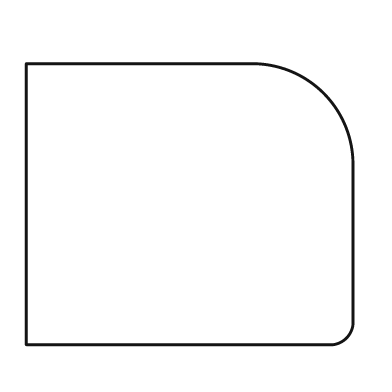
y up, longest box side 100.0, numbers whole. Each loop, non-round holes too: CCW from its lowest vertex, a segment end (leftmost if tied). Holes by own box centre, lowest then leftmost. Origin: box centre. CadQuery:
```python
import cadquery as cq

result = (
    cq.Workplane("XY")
    .moveTo(-50.0, -43.0)
    .lineTo(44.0, -43.0)
    .threePointArc((48.0, -41.0), (50.0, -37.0))
    .lineTo(50.0, 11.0)
    .threePointArc((41.0, 34.0), (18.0, 43.0))
    .lineTo(-50.0, 43.0)
    .close()
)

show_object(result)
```